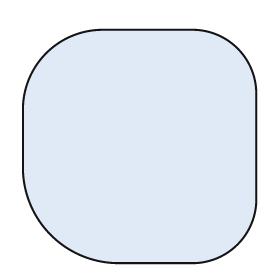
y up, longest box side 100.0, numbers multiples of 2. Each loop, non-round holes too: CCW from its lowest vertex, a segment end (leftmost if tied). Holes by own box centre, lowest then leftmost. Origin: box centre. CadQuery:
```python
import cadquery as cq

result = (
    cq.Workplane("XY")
    .moveTo(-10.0, -50.0)
    .lineTo(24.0, -50.0)
    .threePointArc((42.0, -42.0), (50.0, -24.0))
    .lineTo(50.0, 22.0)
    .threePointArc((42.0, 42.0), (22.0, 50.0))
    .lineTo(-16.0, 50.0)
    .threePointArc((-40.0, 40.0), (-50.0, 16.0))
    .lineTo(-50.0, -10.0)
    .threePointArc((-38.0, -38.0), (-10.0, -50.0))
    .close()
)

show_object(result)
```